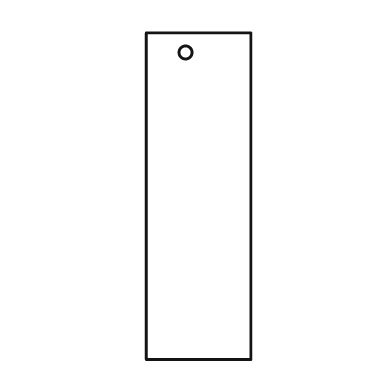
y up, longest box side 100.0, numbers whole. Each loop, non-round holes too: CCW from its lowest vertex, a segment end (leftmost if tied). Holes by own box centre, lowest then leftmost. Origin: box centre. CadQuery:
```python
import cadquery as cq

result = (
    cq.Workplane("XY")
    .moveTo(-16.0, -50.0)
    .lineTo(16.0, -50.0)
    .lineTo(16.0, 50.0)
    .lineTo(-16.0, 50.0)
    .close()
    .moveTo(-4.0, 44.0)
    .circle(2.0)
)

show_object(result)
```